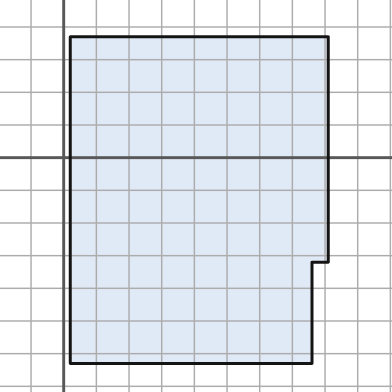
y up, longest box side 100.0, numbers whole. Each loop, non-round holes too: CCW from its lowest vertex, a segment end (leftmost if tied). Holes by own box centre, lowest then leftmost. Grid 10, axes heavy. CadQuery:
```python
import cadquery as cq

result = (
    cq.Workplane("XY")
    .moveTo(2.0, -63.0)
    .lineTo(76.0, -63.0)
    .lineTo(76.0, -32.0)
    .lineTo(81.0, -32.0)
    .lineTo(81.0, 37.0)
    .lineTo(2.0, 37.0)
    .close()
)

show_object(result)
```